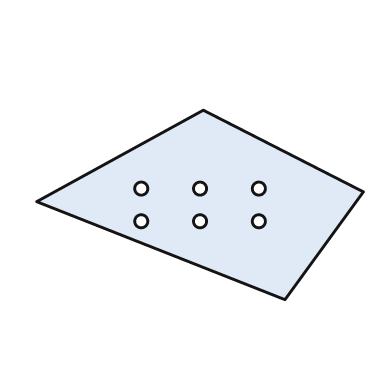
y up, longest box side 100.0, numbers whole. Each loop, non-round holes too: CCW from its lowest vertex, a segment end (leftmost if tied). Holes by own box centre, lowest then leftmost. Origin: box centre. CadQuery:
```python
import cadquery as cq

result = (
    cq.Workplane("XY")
    .moveTo(26.0, -29.0)
    .lineTo(50.0, 4.0)
    .lineTo(1.0, 29.0)
    .lineTo(-50.0, 1.0)
    .close()
    .moveTo(-18.0, -5.0)
    .circle(2.0)
    .moveTo(0.0, -5.0)
    .circle(2.0)
    .moveTo(18.0, -5.0)
    .circle(2.0)
    .moveTo(-18.0, 5.0)
    .circle(2.0)
    .moveTo(0.0, 5.0)
    .circle(2.0)
    .moveTo(18.0, 5.0)
    .circle(2.0)
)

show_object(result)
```